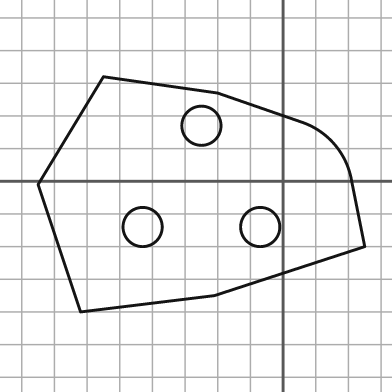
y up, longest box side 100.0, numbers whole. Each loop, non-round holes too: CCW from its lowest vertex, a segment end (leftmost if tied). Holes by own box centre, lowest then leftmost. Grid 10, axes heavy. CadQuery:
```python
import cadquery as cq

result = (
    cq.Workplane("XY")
    .moveTo(-62.0, -40.0)
    .lineTo(-21.0, -35.0)
    .lineTo(25.0, -20.0)
    .lineTo(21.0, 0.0)
    .threePointArc((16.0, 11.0), (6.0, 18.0))
    .lineTo(-20.0, 27.0)
    .lineTo(-55.0, 32.0)
    .lineTo(-75.0, -1.0)
    .close()
    .moveTo(-43.0, -14.0)
    .circle(6.0)
    .moveTo(-7.0, -14.0)
    .circle(6.0)
    .moveTo(-25.0, 17.0)
    .circle(6.0)
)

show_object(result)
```